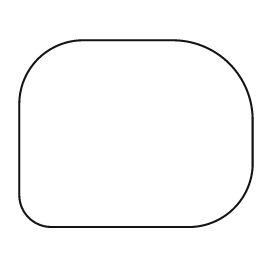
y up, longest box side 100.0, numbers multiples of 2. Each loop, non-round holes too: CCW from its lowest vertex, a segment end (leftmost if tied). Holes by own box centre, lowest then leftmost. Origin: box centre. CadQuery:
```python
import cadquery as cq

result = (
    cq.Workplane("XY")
    .moveTo(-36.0, -40.0)
    .lineTo(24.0, -40.0)
    .threePointArc((42.0, -32.0), (50.0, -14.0))
    .lineTo(50.0, 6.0)
    .threePointArc((40.0, 30.0), (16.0, 40.0))
    .lineTo(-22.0, 40.0)
    .threePointArc((-42.0, 32.0), (-50.0, 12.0))
    .lineTo(-50.0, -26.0)
    .threePointArc((-46.0, -36.0), (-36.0, -40.0))
    .close()
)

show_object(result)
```